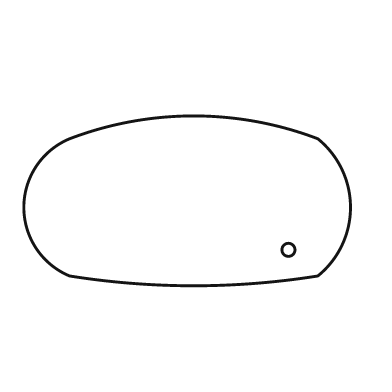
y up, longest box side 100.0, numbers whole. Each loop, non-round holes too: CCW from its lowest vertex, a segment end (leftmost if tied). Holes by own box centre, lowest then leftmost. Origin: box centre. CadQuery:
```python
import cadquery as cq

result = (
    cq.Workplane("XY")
    .moveTo(-36.0, -23.0)
    .threePointArc((2.0, -26.0), (40.0, -23.0))
    .threePointArc((50.0, -2.0), (40.0, 19.0))
    .threePointArc((2.0, 26.0), (-36.0, 19.0))
    .threePointArc((-50.0, -2.0), (-36.0, -23.0))
    .close()
    .moveTo(31.0, -15.0)
    .circle(2.0)
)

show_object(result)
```